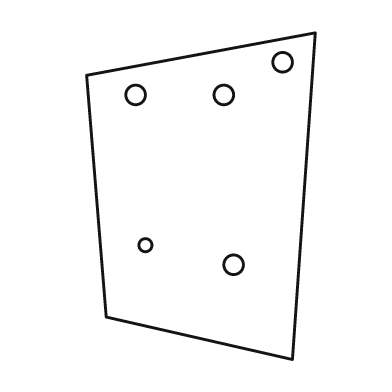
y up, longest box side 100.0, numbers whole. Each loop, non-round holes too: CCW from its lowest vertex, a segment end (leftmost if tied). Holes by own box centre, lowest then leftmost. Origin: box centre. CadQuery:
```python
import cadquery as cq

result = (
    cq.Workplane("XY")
    .moveTo(28.0, -50.0)
    .lineTo(35.0, 50.0)
    .lineTo(-35.0, 37.0)
    .lineTo(-29.0, -37.0)
    .close()
    .moveTo(10.0, -21.0)
    .circle(3.0)
    .moveTo(-17.0, -15.0)
    .circle(2.0)
    .moveTo(-20.0, 31.0)
    .circle(3.0)
    .moveTo(7.0, 31.0)
    .circle(3.0)
    .moveTo(25.0, 41.0)
    .circle(3.0)
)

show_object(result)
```